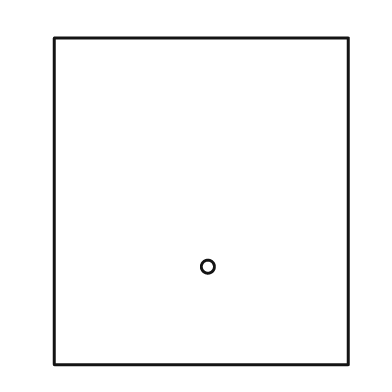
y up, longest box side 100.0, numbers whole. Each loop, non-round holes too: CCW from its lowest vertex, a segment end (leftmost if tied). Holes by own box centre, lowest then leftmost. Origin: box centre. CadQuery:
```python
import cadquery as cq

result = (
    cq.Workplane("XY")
    .moveTo(-45.0, -50.0)
    .lineTo(45.0, -50.0)
    .lineTo(45.0, 50.0)
    .lineTo(-45.0, 50.0)
    .close()
    .moveTo(2.0, -20.0)
    .circle(2.0)
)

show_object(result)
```